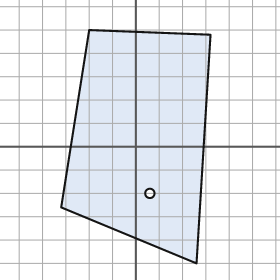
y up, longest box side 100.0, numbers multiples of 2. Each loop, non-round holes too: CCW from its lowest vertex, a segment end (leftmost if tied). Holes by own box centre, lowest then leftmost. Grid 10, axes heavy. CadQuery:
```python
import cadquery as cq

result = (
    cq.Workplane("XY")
    .moveTo(26.0, -50.0)
    .lineTo(32.0, 48.0)
    .lineTo(-20.0, 50.0)
    .lineTo(-32.0, -26.0)
    .close()
    .moveTo(6.0, -20.0)
    .circle(2.0)
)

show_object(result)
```